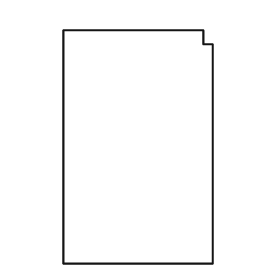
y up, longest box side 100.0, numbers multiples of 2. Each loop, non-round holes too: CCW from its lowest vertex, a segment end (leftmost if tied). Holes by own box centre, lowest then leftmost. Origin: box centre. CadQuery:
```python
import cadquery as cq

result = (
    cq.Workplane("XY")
    .moveTo(-32.0, -50.0)
    .lineTo(32.0, -50.0)
    .lineTo(32.0, 44.0)
    .lineTo(28.0, 44.0)
    .lineTo(28.0, 50.0)
    .lineTo(-32.0, 50.0)
    .close()
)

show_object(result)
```